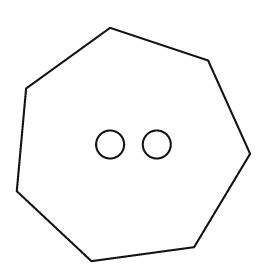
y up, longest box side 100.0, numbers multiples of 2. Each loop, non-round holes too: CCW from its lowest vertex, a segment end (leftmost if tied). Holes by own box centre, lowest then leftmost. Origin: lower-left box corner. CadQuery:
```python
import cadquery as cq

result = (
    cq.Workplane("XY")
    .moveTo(32.0, 0.0)
    .lineTo(76.0, 6.0)
    .lineTo(100.0, 46.0)
    .lineTo(82.0, 86.0)
    .lineTo(40.0, 100.0)
    .lineTo(4.0, 74.0)
    .lineTo(0.0, 30.0)
    .close()
    .moveTo(40.0, 50.0)
    .circle(6.0)
    .moveTo(60.0, 50.0)
    .circle(6.0)
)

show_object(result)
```